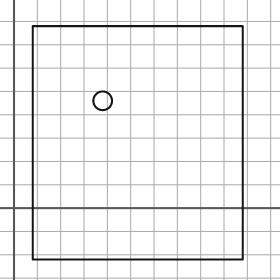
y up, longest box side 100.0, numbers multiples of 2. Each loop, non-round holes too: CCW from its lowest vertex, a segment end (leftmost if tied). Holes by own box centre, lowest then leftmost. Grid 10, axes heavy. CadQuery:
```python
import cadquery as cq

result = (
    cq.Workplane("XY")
    .moveTo(8.0, -22.0)
    .lineTo(98.0, -22.0)
    .lineTo(98.0, 78.0)
    .lineTo(8.0, 78.0)
    .close()
    .moveTo(38.0, 46.0)
    .circle(4.0)
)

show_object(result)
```